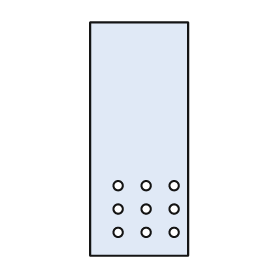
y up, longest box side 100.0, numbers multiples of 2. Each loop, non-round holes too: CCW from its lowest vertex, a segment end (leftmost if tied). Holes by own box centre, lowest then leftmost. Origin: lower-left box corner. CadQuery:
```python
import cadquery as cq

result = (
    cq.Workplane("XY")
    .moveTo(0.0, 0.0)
    .lineTo(42.0, 0.0)
    .lineTo(42.0, 100.0)
    .lineTo(0.0, 100.0)
    .close()
    .moveTo(12.0, 10.0)
    .circle(2.0)
    .moveTo(24.0, 10.0)
    .circle(2.0)
    .moveTo(36.0, 10.0)
    .circle(2.0)
    .moveTo(12.0, 20.0)
    .circle(2.0)
    .moveTo(24.0, 20.0)
    .circle(2.0)
    .moveTo(36.0, 20.0)
    .circle(2.0)
    .moveTo(12.0, 30.0)
    .circle(2.0)
    .moveTo(24.0, 30.0)
    .circle(2.0)
    .moveTo(36.0, 30.0)
    .circle(2.0)
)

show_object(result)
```